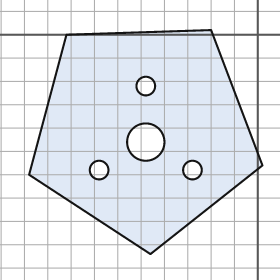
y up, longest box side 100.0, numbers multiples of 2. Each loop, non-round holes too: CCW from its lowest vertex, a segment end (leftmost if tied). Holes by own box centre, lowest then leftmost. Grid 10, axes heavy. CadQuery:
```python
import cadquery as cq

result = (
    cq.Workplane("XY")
    .moveTo(-46.0, -94.0)
    .lineTo(2.0, -56.0)
    .lineTo(-20.0, 2.0)
    .lineTo(-82.0, 0.0)
    .lineTo(-98.0, -60.0)
    .close()
    .moveTo(-68.0, -58.0)
    .circle(4.0)
    .moveTo(-28.0, -58.0)
    .circle(4.0)
    .moveTo(-48.0, -46.0)
    .circle(8.0)
    .moveTo(-48.0, -22.0)
    .circle(4.0)
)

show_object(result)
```